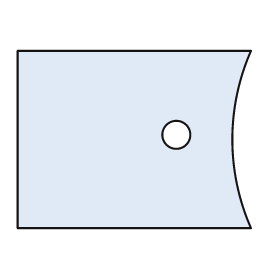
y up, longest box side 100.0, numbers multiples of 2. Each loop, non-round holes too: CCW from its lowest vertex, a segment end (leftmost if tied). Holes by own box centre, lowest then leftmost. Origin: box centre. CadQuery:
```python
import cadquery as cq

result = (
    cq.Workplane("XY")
    .moveTo(-50.0, -38.0)
    .lineTo(50.0, -38.0)
    .threePointArc((42.0, 0.0), (50.0, 38.0))
    .lineTo(-50.0, 38.0)
    .close()
    .moveTo(18.0, 2.0)
    .circle(6.0)
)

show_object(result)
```